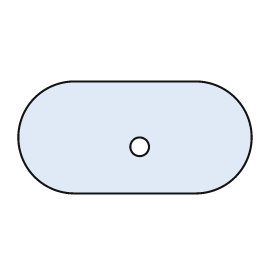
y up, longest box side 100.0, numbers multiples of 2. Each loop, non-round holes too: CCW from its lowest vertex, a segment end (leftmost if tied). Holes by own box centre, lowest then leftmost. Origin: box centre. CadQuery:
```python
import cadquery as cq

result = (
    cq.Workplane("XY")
    .moveTo(-26.0, -24.0)
    .lineTo(26.0, -24.0)
    .threePointArc((50.0, 0.0), (26.0, 24.0))
    .lineTo(-26.0, 24.0)
    .threePointArc((-50.0, 0.0), (-26.0, -24.0))
    .close()
    .moveTo(2.0, -4.0)
    .circle(4.0)
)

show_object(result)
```